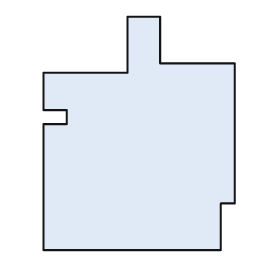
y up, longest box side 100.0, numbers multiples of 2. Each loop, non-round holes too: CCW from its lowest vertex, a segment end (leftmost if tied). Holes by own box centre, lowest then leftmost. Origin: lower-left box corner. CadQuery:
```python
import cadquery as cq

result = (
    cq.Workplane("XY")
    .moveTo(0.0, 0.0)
    .lineTo(76.0, 0.0)
    .lineTo(76.0, 20.0)
    .lineTo(82.0, 20.0)
    .lineTo(82.0, 80.0)
    .lineTo(50.0, 80.0)
    .lineTo(50.0, 100.0)
    .lineTo(36.0, 100.0)
    .lineTo(36.0, 76.0)
    .lineTo(0.0, 76.0)
    .lineTo(0.0, 60.0)
    .lineTo(10.0, 60.0)
    .lineTo(10.0, 54.0)
    .lineTo(0.0, 54.0)
    .close()
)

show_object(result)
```